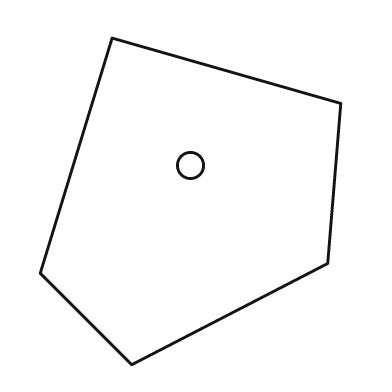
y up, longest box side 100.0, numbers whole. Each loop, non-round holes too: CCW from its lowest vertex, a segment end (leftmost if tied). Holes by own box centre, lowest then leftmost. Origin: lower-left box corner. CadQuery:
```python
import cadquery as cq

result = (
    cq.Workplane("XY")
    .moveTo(28.0, 0.0)
    .lineTo(88.0, 31.0)
    .lineTo(92.0, 80.0)
    .lineTo(22.0, 100.0)
    .lineTo(0.0, 28.0)
    .close()
    .moveTo(46.0, 61.0)
    .circle(4.0)
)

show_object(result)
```